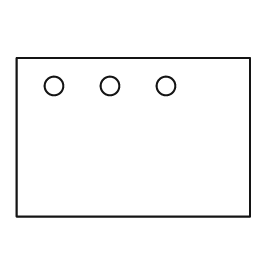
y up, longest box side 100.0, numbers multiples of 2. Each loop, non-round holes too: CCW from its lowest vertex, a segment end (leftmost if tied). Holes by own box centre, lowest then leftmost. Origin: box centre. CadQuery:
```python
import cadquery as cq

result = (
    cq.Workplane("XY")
    .moveTo(-50.0, -34.0)
    .lineTo(50.0, -34.0)
    .lineTo(50.0, 34.0)
    .lineTo(-50.0, 34.0)
    .close()
    .moveTo(-34.0, 22.0)
    .circle(4.0)
    .moveTo(-10.0, 22.0)
    .circle(4.0)
    .moveTo(14.0, 22.0)
    .circle(4.0)
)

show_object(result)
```